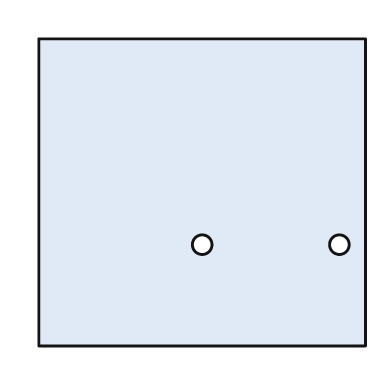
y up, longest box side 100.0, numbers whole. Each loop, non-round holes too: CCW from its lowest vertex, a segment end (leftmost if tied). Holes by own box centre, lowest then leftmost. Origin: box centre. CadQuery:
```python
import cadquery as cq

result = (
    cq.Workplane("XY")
    .moveTo(-50.0, -47.0)
    .lineTo(50.0, -47.0)
    .lineTo(50.0, 47.0)
    .lineTo(-50.0, 47.0)
    .close()
    .moveTo(0.0, -16.0)
    .circle(3.0)
    .moveTo(42.0, -16.0)
    .circle(3.0)
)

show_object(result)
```